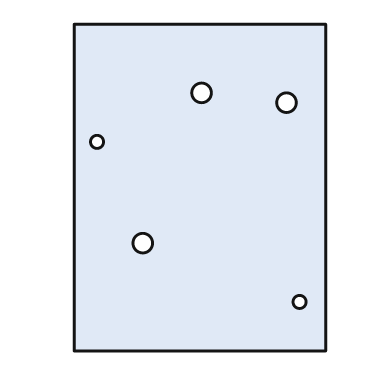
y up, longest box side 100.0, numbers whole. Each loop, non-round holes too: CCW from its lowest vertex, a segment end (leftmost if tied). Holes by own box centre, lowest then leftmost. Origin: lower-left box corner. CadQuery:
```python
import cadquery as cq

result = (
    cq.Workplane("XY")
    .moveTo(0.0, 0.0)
    .lineTo(77.0, 0.0)
    .lineTo(77.0, 100.0)
    .lineTo(0.0, 100.0)
    .close()
    .moveTo(69.0, 15.0)
    .circle(2.0)
    .moveTo(21.0, 33.0)
    .circle(3.0)
    .moveTo(7.0, 64.0)
    .circle(2.0)
    .moveTo(65.0, 76.0)
    .circle(3.0)
    .moveTo(39.0, 79.0)
    .circle(3.0)
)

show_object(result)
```